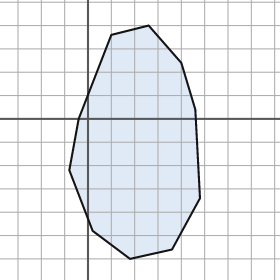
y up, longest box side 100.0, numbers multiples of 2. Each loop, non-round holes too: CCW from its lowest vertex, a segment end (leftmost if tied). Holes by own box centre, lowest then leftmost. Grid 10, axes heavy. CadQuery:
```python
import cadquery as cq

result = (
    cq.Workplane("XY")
    .moveTo(18.0, -60.0)
    .lineTo(36.0, -56.0)
    .lineTo(48.0, -34.0)
    .lineTo(46.0, 4.0)
    .lineTo(40.0, 24.0)
    .lineTo(26.0, 40.0)
    .lineTo(10.0, 36.0)
    .lineTo(-4.0, 0.0)
    .lineTo(-8.0, -22.0)
    .lineTo(2.0, -48.0)
    .close()
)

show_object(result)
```